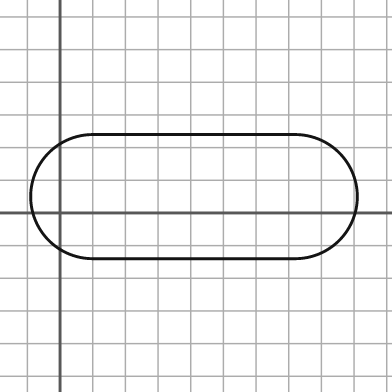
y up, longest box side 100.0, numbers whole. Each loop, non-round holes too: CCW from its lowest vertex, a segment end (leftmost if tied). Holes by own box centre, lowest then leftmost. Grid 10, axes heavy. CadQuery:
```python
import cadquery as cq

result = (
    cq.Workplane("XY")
    .moveTo(10.0, -14.0)
    .lineTo(72.0, -14.0)
    .threePointArc((91.0, 5.0), (72.0, 24.0))
    .lineTo(10.0, 24.0)
    .threePointArc((-9.0, 5.0), (10.0, -14.0))
    .close()
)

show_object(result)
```